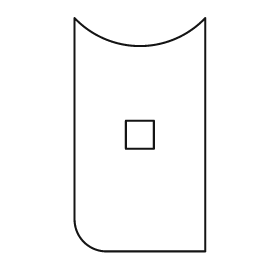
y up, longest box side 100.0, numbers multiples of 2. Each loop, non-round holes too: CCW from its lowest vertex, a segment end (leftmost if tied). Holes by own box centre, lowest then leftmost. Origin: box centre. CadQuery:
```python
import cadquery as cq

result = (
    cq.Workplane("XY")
    .moveTo(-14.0, -50.0)
    .lineTo(28.0, -50.0)
    .lineTo(28.0, 50.0)
    .threePointArc((0.0, 38.0), (-28.0, 50.0))
    .lineTo(-28.0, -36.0)
    .threePointArc((-24.0, -46.0), (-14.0, -50.0))
    .close()
    .moveTo(-6.0, -6.0)
    .lineTo(6.0, -6.0)
    .lineTo(6.0, 6.0)
    .lineTo(-6.0, 6.0)
    .close()
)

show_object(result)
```